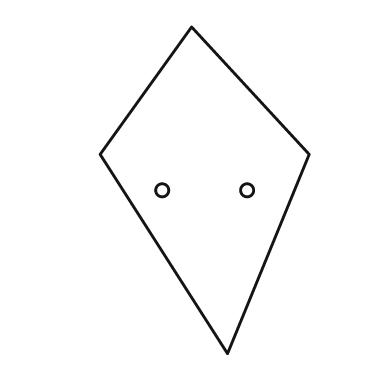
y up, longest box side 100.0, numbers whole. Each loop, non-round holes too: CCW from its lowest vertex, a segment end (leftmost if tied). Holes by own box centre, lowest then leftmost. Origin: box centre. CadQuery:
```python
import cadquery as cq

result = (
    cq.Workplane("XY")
    .moveTo(7.0, -50.0)
    .lineTo(32.0, 11.0)
    .lineTo(-4.0, 50.0)
    .lineTo(-32.0, 11.0)
    .close()
    .moveTo(-13.0, 0.0)
    .circle(2.0)
    .moveTo(13.0, 0.0)
    .circle(2.0)
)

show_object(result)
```